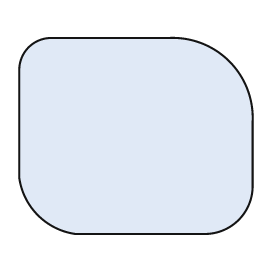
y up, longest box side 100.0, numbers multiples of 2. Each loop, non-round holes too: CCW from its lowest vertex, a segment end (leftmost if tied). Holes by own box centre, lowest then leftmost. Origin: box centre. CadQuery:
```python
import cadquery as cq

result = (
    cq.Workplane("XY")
    .moveTo(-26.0, -42.0)
    .lineTo(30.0, -42.0)
    .threePointArc((44.0, -36.0), (50.0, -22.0))
    .lineTo(50.0, 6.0)
    .threePointArc((40.0, 32.0), (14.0, 42.0))
    .lineTo(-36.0, 42.0)
    .threePointArc((-46.0, 38.0), (-50.0, 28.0))
    .lineTo(-50.0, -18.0)
    .threePointArc((-42.0, -34.0), (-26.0, -42.0))
    .close()
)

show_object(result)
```